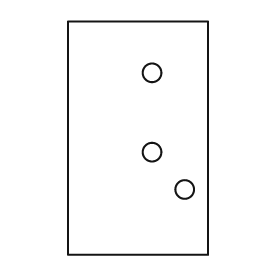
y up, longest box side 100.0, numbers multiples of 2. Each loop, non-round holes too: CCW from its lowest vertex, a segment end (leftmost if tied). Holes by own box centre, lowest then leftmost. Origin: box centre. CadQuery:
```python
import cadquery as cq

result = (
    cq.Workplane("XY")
    .moveTo(-30.0, -50.0)
    .lineTo(30.0, -50.0)
    .lineTo(30.0, 50.0)
    .lineTo(-30.0, 50.0)
    .close()
    .moveTo(20.0, -22.0)
    .circle(4.0)
    .moveTo(6.0, -6.0)
    .circle(4.0)
    .moveTo(6.0, 28.0)
    .circle(4.0)
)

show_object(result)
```